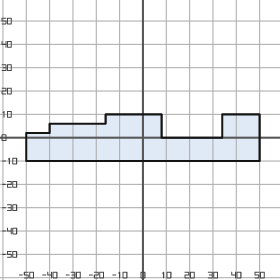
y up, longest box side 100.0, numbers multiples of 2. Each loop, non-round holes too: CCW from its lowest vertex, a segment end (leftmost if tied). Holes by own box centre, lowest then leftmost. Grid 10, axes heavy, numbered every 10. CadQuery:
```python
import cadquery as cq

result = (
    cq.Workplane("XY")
    .moveTo(-50.0, -10.0)
    .lineTo(50.0, -10.0)
    .lineTo(50.0, 10.0)
    .lineTo(34.0, 10.0)
    .lineTo(34.0, 0.0)
    .lineTo(8.0, 0.0)
    .lineTo(8.0, 10.0)
    .lineTo(-16.0, 10.0)
    .lineTo(-16.0, 6.0)
    .lineTo(-40.0, 6.0)
    .lineTo(-40.0, 2.0)
    .lineTo(-50.0, 2.0)
    .close()
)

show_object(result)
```